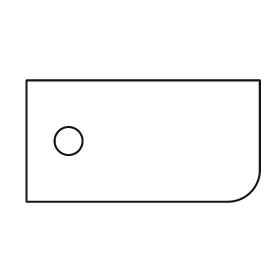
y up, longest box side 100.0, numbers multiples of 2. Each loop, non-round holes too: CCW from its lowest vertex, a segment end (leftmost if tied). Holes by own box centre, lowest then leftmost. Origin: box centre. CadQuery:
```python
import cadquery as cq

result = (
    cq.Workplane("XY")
    .moveTo(-50.0, -26.0)
    .lineTo(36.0, -26.0)
    .threePointArc((46.0, -22.0), (50.0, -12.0))
    .lineTo(50.0, 26.0)
    .lineTo(-50.0, 26.0)
    .close()
    .moveTo(-32.0, 0.0)
    .circle(6.0)
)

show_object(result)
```